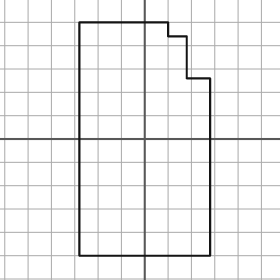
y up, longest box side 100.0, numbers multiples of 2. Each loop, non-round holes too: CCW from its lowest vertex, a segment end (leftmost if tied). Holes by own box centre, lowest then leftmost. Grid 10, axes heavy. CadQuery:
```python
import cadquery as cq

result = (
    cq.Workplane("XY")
    .moveTo(-28.0, -50.0)
    .lineTo(28.0, -50.0)
    .lineTo(28.0, 26.0)
    .lineTo(18.0, 26.0)
    .lineTo(18.0, 44.0)
    .lineTo(10.0, 44.0)
    .lineTo(10.0, 50.0)
    .lineTo(-28.0, 50.0)
    .close()
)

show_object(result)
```